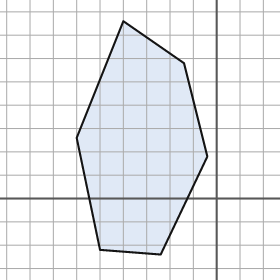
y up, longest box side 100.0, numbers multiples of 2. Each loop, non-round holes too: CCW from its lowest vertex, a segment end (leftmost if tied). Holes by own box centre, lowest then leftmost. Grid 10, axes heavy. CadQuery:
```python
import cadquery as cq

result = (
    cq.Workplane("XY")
    .moveTo(-24.0, -24.0)
    .lineTo(-4.0, 18.0)
    .lineTo(-14.0, 58.0)
    .lineTo(-40.0, 76.0)
    .lineTo(-60.0, 26.0)
    .lineTo(-50.0, -22.0)
    .close()
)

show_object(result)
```